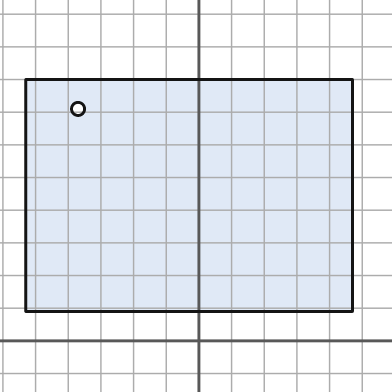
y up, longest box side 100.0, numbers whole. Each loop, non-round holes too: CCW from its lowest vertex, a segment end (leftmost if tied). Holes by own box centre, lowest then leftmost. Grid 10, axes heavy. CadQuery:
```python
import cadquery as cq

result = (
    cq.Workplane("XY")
    .moveTo(-53.0, 9.0)
    .lineTo(47.0, 9.0)
    .lineTo(47.0, 80.0)
    .lineTo(-53.0, 80.0)
    .close()
    .moveTo(-37.0, 71.0)
    .circle(2.0)
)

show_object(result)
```